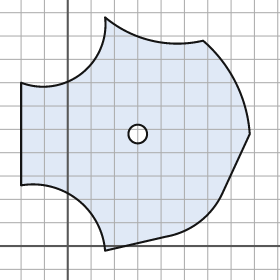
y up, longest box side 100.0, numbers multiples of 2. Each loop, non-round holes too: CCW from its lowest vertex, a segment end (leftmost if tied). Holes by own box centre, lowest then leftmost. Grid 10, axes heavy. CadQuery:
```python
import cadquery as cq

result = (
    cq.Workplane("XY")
    .moveTo(16.0, -2.0)
    .lineTo(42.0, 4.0)
    .threePointArc((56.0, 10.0), (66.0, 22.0))
    .lineTo(78.0, 48.0)
    .threePointArc((72.0, 70.0), (58.0, 88.0))
    .threePointArc((36.0, 88.0), (16.0, 98.0))
    .threePointArc((6.0, 74.0), (-20.0, 70.0))
    .lineTo(-20.0, 26.0)
    .threePointArc((4.0, 20.0), (16.0, -2.0))
    .close()
    .moveTo(30.0, 48.0)
    .circle(4.0)
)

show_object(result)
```